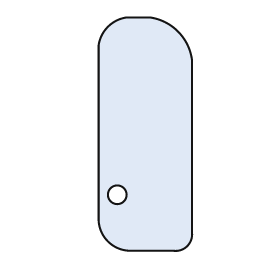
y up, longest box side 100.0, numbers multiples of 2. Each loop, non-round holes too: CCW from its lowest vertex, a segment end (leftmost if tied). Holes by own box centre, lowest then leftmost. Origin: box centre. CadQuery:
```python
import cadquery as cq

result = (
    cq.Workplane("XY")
    .moveTo(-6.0, -50.0)
    .lineTo(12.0, -50.0)
    .threePointArc((18.0, -48.0), (20.0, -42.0))
    .lineTo(20.0, 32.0)
    .threePointArc((14.0, 44.0), (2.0, 50.0))
    .lineTo(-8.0, 50.0)
    .threePointArc((-16.0, 46.0), (-20.0, 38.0))
    .lineTo(-20.0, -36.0)
    .threePointArc((-16.0, -46.0), (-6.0, -50.0))
    .close()
    .moveTo(-12.0, -26.0)
    .circle(4.0)
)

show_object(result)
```